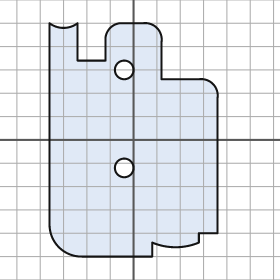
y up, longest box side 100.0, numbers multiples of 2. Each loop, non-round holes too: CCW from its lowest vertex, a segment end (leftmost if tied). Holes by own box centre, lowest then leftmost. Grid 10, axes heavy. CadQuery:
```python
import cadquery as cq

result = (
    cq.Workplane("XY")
    .moveTo(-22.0, -50.0)
    .lineTo(8.0, -50.0)
    .lineTo(8.0, -44.0)
    .threePointArc((18.0, -46.0), (28.0, -44.0))
    .lineTo(28.0, -40.0)
    .lineTo(36.0, -40.0)
    .lineTo(36.0, 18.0)
    .threePointArc((34.0, 24.0), (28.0, 26.0))
    .lineTo(12.0, 26.0)
    .lineTo(12.0, 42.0)
    .threePointArc((10.0, 48.0), (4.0, 50.0))
    .lineTo(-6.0, 50.0)
    .threePointArc((-10.0, 48.0), (-12.0, 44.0))
    .lineTo(-12.0, 34.0)
    .lineTo(-24.0, 34.0)
    .lineTo(-24.0, 50.0)
    .threePointArc((-30.0, 48.0), (-36.0, 50.0))
    .lineTo(-36.0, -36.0)
    .threePointArc((-32.0, -46.0), (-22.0, -50.0))
    .close()
    .moveTo(-4.0, -12.0)
    .circle(4.0)
    .moveTo(-4.0, 30.0)
    .circle(4.0)
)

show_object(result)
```